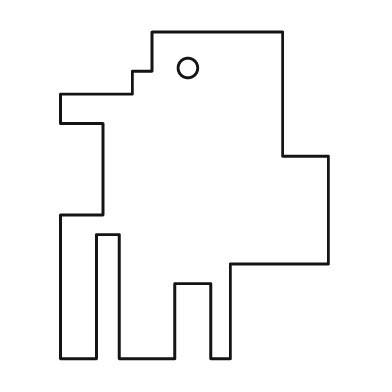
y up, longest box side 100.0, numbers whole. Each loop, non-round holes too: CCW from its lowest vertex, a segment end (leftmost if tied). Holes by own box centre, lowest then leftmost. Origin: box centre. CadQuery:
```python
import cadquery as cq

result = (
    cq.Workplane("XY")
    .moveTo(-41.0, -50.0)
    .lineTo(-30.0, -50.0)
    .lineTo(-30.0, -12.0)
    .lineTo(-23.0, -12.0)
    .lineTo(-23.0, -50.0)
    .lineTo(-6.0, -50.0)
    .lineTo(-6.0, -27.0)
    .lineTo(5.0, -27.0)
    .lineTo(5.0, -50.0)
    .lineTo(11.0, -50.0)
    .lineTo(11.0, -21.0)
    .lineTo(41.0, -21.0)
    .lineTo(41.0, 12.0)
    .lineTo(27.0, 12.0)
    .lineTo(27.0, 50.0)
    .lineTo(-13.0, 50.0)
    .lineTo(-13.0, 38.0)
    .lineTo(-19.0, 38.0)
    .lineTo(-19.0, 31.0)
    .lineTo(-41.0, 31.0)
    .lineTo(-41.0, 22.0)
    .lineTo(-28.0, 22.0)
    .lineTo(-28.0, -6.0)
    .lineTo(-41.0, -6.0)
    .close()
    .moveTo(-2.0, 39.0)
    .circle(3.0)
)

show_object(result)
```